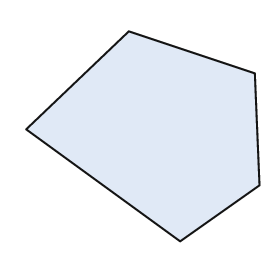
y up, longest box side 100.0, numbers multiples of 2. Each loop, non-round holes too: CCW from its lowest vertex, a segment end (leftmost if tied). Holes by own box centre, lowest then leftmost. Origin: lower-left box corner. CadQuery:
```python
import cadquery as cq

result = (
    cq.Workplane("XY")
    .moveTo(66.0, 0.0)
    .lineTo(100.0, 24.0)
    .lineTo(98.0, 72.0)
    .lineTo(44.0, 90.0)
    .lineTo(0.0, 48.0)
    .close()
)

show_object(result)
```